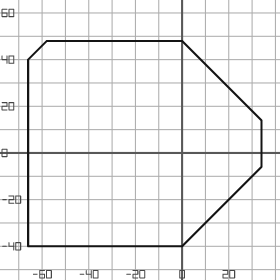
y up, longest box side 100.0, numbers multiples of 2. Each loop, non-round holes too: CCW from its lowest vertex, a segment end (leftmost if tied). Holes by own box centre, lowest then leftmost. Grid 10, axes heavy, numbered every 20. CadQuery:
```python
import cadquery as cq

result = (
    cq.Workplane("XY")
    .moveTo(-66.0, -40.0)
    .lineTo(0.0, -40.0)
    .lineTo(34.0, -6.0)
    .lineTo(34.0, 14.0)
    .lineTo(0.0, 48.0)
    .lineTo(-58.0, 48.0)
    .lineTo(-66.0, 40.0)
    .close()
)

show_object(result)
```